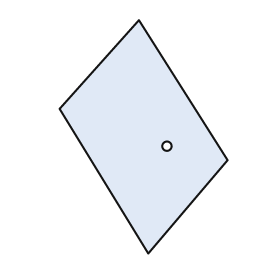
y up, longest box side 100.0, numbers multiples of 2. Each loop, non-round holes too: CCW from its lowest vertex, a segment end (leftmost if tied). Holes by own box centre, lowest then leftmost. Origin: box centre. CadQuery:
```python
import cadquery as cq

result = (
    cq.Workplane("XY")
    .moveTo(2.0, -50.0)
    .lineTo(36.0, -10.0)
    .lineTo(-2.0, 50.0)
    .lineTo(-36.0, 12.0)
    .close()
    .moveTo(10.0, -4.0)
    .circle(2.0)
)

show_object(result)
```